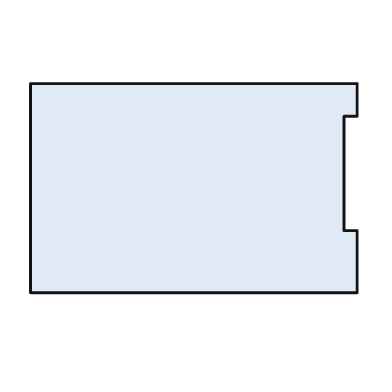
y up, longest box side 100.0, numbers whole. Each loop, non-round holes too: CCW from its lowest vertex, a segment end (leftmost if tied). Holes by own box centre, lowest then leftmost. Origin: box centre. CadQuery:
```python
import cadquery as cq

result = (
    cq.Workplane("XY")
    .moveTo(-50.0, -32.0)
    .lineTo(50.0, -32.0)
    .lineTo(50.0, -13.0)
    .lineTo(46.0, -13.0)
    .lineTo(46.0, 22.0)
    .lineTo(50.0, 22.0)
    .lineTo(50.0, 32.0)
    .lineTo(-50.0, 32.0)
    .close()
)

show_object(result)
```